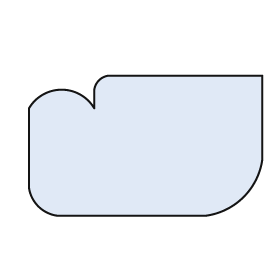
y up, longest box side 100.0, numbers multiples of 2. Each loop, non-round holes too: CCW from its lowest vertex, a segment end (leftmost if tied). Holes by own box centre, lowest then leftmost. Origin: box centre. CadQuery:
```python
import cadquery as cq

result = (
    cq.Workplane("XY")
    .moveTo(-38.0, -30.0)
    .lineTo(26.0, -30.0)
    .threePointArc((42.0, -22.0), (50.0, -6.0))
    .lineTo(50.0, 30.0)
    .lineTo(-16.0, 30.0)
    .threePointArc((-20.0, 28.0), (-22.0, 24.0))
    .lineTo(-22.0, 16.0)
    .threePointArc((-36.0, 24.0), (-50.0, 16.0))
    .lineTo(-50.0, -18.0)
    .threePointArc((-46.0, -26.0), (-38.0, -30.0))
    .close()
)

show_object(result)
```